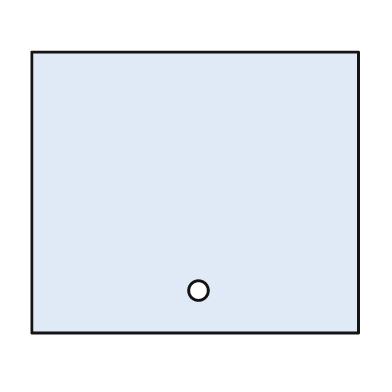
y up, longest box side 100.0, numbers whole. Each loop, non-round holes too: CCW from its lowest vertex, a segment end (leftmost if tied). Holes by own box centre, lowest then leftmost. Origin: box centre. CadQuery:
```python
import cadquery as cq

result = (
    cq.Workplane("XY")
    .moveTo(-50.0, -43.0)
    .lineTo(50.0, -43.0)
    .lineTo(50.0, 43.0)
    .lineTo(-50.0, 43.0)
    .close()
    .moveTo(1.0, -30.0)
    .circle(3.0)
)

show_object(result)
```